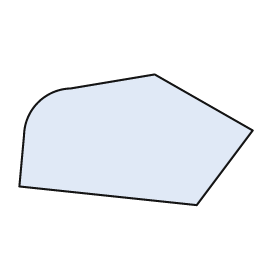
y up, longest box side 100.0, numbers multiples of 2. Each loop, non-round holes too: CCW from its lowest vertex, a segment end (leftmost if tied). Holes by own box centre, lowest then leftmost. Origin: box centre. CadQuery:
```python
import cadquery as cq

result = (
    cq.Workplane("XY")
    .moveTo(26.0, -28.0)
    .lineTo(50.0, 4.0)
    .lineTo(8.0, 28.0)
    .lineTo(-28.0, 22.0)
    .threePointArc((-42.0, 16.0), (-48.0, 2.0))
    .lineTo(-50.0, -20.0)
    .close()
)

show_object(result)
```